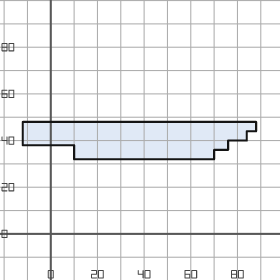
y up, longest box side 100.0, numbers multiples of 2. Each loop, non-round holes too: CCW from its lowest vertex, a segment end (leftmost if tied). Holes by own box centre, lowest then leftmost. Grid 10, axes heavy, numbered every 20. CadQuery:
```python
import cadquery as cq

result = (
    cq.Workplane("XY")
    .moveTo(10.0, 32.0)
    .lineTo(70.0, 32.0)
    .lineTo(70.0, 36.0)
    .lineTo(76.0, 36.0)
    .lineTo(76.0, 40.0)
    .lineTo(84.0, 40.0)
    .lineTo(84.0, 44.0)
    .lineTo(88.0, 44.0)
    .lineTo(88.0, 48.0)
    .lineTo(-12.0, 48.0)
    .lineTo(-12.0, 38.0)
    .lineTo(10.0, 38.0)
    .close()
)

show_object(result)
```